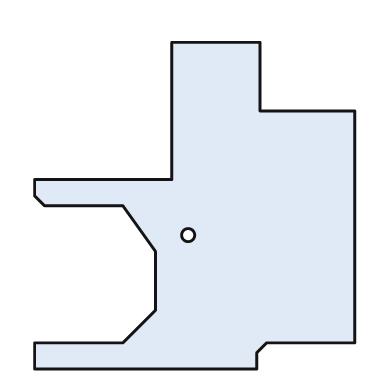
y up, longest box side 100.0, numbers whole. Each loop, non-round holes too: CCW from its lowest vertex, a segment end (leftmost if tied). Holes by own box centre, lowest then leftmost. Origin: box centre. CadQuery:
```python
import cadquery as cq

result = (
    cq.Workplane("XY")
    .moveTo(-49.0, -50.0)
    .lineTo(19.0, -50.0)
    .lineTo(19.0, -45.0)
    .lineTo(22.0, -42.0)
    .lineTo(49.0, -42.0)
    .lineTo(49.0, 29.0)
    .lineTo(20.0, 29.0)
    .lineTo(20.0, 50.0)
    .lineTo(-7.0, 50.0)
    .lineTo(-7.0, 8.0)
    .lineTo(-49.0, 8.0)
    .lineTo(-49.0, 3.0)
    .lineTo(-46.0, 0.0)
    .lineTo(-22.0, 0.0)
    .lineTo(-12.0, -14.0)
    .lineTo(-12.0, -32.0)
    .lineTo(-22.0, -42.0)
    .lineTo(-49.0, -42.0)
    .close()
    .moveTo(-2.0, -9.0)
    .circle(2.0)
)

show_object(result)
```